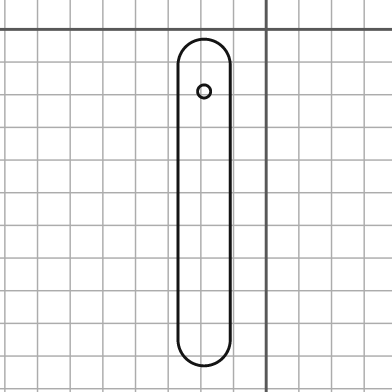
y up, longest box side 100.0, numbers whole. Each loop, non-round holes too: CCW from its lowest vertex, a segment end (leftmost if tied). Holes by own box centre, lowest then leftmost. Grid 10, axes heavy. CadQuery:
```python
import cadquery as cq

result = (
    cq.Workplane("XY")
    .moveTo(-27.0, -95.0)
    .threePointArc((-19.0, -103.0), (-11.0, -95.0))
    .lineTo(-11.0, -11.0)
    .threePointArc((-19.0, -3.0), (-27.0, -11.0))
    .close()
    .moveTo(-19.0, -19.0)
    .circle(2.0)
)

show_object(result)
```